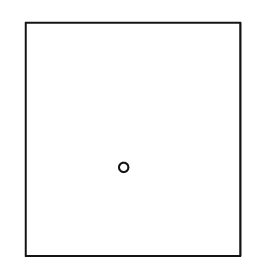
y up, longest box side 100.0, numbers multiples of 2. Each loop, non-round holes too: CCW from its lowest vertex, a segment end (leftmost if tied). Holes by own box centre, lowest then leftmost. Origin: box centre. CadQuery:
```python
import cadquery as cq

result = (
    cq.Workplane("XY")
    .moveTo(-46.0, -50.0)
    .lineTo(46.0, -50.0)
    .lineTo(46.0, 50.0)
    .lineTo(-46.0, 50.0)
    .close()
    .moveTo(-4.0, -12.0)
    .circle(2.0)
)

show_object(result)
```